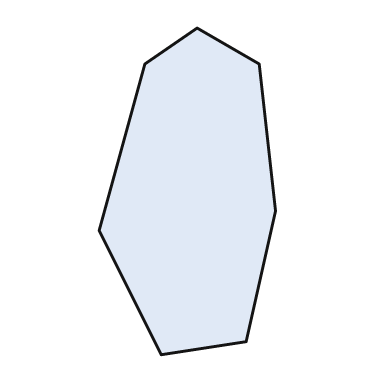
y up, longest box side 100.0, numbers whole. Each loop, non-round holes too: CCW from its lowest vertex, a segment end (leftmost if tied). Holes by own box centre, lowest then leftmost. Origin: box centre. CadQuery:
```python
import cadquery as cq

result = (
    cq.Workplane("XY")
    .moveTo(-8.0, -50.0)
    .lineTo(18.0, -46.0)
    .lineTo(27.0, -6.0)
    .lineTo(22.0, 39.0)
    .lineTo(3.0, 50.0)
    .lineTo(-13.0, 39.0)
    .lineTo(-27.0, -12.0)
    .close()
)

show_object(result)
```